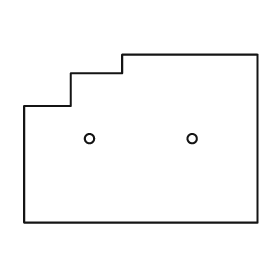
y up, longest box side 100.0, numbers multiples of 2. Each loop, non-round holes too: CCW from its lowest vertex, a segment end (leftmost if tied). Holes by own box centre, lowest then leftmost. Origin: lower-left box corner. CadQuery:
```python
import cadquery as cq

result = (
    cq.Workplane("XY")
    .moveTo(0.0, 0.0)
    .lineTo(100.0, 0.0)
    .lineTo(100.0, 72.0)
    .lineTo(42.0, 72.0)
    .lineTo(42.0, 64.0)
    .lineTo(20.0, 64.0)
    .lineTo(20.0, 50.0)
    .lineTo(0.0, 50.0)
    .close()
    .moveTo(28.0, 36.0)
    .circle(2.0)
    .moveTo(72.0, 36.0)
    .circle(2.0)
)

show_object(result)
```